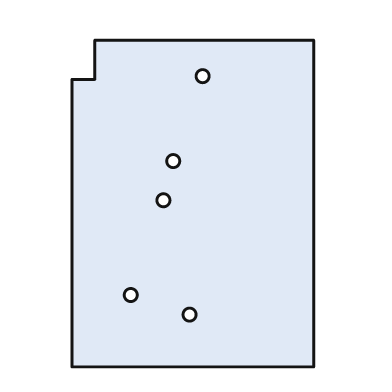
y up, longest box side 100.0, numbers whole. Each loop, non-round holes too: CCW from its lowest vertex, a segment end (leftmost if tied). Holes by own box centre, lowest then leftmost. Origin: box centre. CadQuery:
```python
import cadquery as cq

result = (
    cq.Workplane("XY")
    .moveTo(-37.0, -50.0)
    .lineTo(37.0, -50.0)
    .lineTo(37.0, 50.0)
    .lineTo(-30.0, 50.0)
    .lineTo(-30.0, 38.0)
    .lineTo(-37.0, 38.0)
    .close()
    .moveTo(-1.0, -34.0)
    .circle(2.0)
    .moveTo(-19.0, -28.0)
    .circle(2.0)
    .moveTo(-9.0, 1.0)
    .circle(2.0)
    .moveTo(-6.0, 13.0)
    .circle(2.0)
    .moveTo(3.0, 39.0)
    .circle(2.0)
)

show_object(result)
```